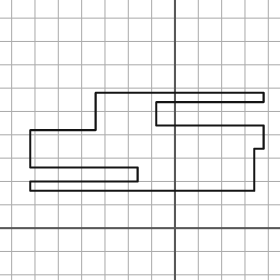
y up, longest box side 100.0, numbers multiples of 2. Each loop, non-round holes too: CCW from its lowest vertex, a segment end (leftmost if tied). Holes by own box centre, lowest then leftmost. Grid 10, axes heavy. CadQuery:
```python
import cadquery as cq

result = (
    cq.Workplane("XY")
    .moveTo(-62.0, 16.0)
    .lineTo(34.0, 16.0)
    .lineTo(34.0, 34.0)
    .lineTo(38.0, 34.0)
    .lineTo(38.0, 44.0)
    .lineTo(-8.0, 44.0)
    .lineTo(-8.0, 54.0)
    .lineTo(38.0, 54.0)
    .lineTo(38.0, 58.0)
    .lineTo(-34.0, 58.0)
    .lineTo(-34.0, 42.0)
    .lineTo(-62.0, 42.0)
    .lineTo(-62.0, 26.0)
    .lineTo(-16.0, 26.0)
    .lineTo(-16.0, 20.0)
    .lineTo(-62.0, 20.0)
    .close()
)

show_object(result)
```